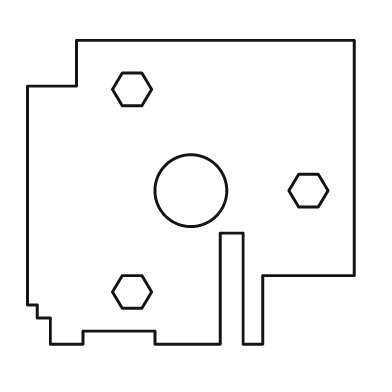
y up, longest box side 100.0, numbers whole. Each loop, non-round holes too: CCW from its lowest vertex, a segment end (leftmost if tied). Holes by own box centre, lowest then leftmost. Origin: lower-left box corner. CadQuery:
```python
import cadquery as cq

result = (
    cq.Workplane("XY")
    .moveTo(7.0, 0.0)
    .lineTo(17.0, 0.0)
    .lineTo(17.0, 4.0)
    .lineTo(39.0, 4.0)
    .lineTo(39.0, 0.0)
    .lineTo(59.0, 0.0)
    .lineTo(59.0, 34.0)
    .lineTo(66.0, 34.0)
    .lineTo(66.0, 0.0)
    .lineTo(72.0, 0.0)
    .lineTo(72.0, 21.0)
    .lineTo(100.0, 21.0)
    .lineTo(100.0, 93.0)
    .lineTo(15.0, 93.0)
    .lineTo(15.0, 79.0)
    .lineTo(0.0, 79.0)
    .lineTo(0.0, 12.0)
    .lineTo(3.0, 12.0)
    .lineTo(3.0, 8.0)
    .lineTo(7.0, 8.0)
    .close()
    .moveTo(29.0, 11.0)
    .lineTo(35.0, 11.0)
    .lineTo(38.0, 16.0)
    .lineTo(35.0, 21.0)
    .lineTo(29.0, 21.0)
    .lineTo(26.0, 16.0)
    .close()
    .moveTo(50.0, 47.0)
    .circle(11.0)
    .moveTo(83.0, 42.0)
    .lineTo(89.0, 42.0)
    .lineTo(92.0, 47.0)
    .lineTo(89.0, 52.0)
    .lineTo(83.0, 52.0)
    .lineTo(80.0, 47.0)
    .close()
    .moveTo(29.0, 73.0)
    .lineTo(35.0, 73.0)
    .lineTo(38.0, 78.0)
    .lineTo(35.0, 83.0)
    .lineTo(29.0, 83.0)
    .lineTo(26.0, 78.0)
    .close()
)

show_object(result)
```